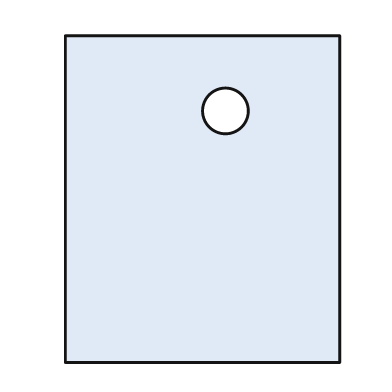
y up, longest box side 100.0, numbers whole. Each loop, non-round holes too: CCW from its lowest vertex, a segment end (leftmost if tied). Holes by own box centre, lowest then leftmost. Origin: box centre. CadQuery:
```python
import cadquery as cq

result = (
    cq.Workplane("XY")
    .moveTo(-42.0, -50.0)
    .lineTo(42.0, -50.0)
    .lineTo(42.0, 50.0)
    .lineTo(-42.0, 50.0)
    .close()
    .moveTo(7.0, 27.0)
    .circle(7.0)
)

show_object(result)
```